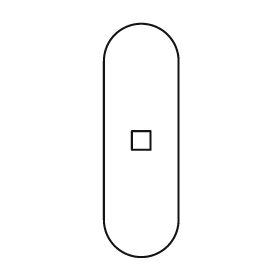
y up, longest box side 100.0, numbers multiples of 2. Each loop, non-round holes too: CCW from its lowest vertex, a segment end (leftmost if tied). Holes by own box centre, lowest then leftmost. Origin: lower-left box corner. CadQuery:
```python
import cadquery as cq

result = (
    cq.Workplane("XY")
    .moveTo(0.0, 16.0)
    .threePointArc((16.0, 0.0), (32.0, 16.0))
    .lineTo(32.0, 84.0)
    .threePointArc((16.0, 100.0), (0.0, 84.0))
    .close()
    .moveTo(12.0, 46.0)
    .lineTo(20.0, 46.0)
    .lineTo(20.0, 54.0)
    .lineTo(12.0, 54.0)
    .close()
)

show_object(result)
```